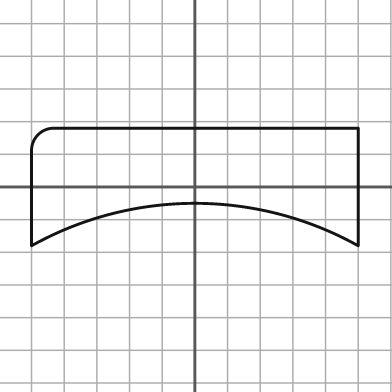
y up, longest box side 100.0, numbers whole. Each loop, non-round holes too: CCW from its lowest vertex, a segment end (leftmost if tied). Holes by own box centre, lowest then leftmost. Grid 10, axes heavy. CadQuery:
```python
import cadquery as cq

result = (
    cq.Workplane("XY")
    .moveTo(-50.0, -18.0)
    .threePointArc((0.0, -5.0), (50.0, -18.0))
    .lineTo(50.0, 18.0)
    .lineTo(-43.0, 18.0)
    .threePointArc((-48.0, 16.0), (-50.0, 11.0))
    .close()
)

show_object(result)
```